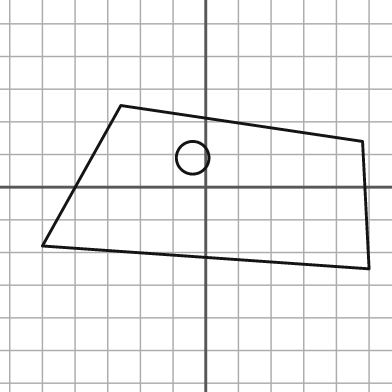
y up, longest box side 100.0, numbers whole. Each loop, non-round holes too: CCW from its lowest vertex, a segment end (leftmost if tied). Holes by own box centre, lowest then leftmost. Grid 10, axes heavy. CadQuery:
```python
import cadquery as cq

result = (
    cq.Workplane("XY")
    .moveTo(50.0, -25.0)
    .lineTo(48.0, 14.0)
    .lineTo(-26.0, 25.0)
    .lineTo(-50.0, -18.0)
    .close()
    .moveTo(-4.0, 9.0)
    .circle(5.0)
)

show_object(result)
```